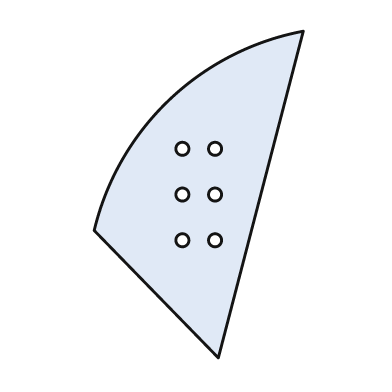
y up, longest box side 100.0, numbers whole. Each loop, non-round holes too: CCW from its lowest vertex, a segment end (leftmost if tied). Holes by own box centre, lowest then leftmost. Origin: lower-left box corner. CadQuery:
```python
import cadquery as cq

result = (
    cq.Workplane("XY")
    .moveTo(38.0, 0.0)
    .lineTo(64.0, 100.0)
    .threePointArc((23.0, 79.0), (0.0, 39.0))
    .close()
    .moveTo(27.0, 36.0)
    .circle(2.0)
    .moveTo(37.0, 36.0)
    .circle(2.0)
    .moveTo(27.0, 50.0)
    .circle(2.0)
    .moveTo(37.0, 50.0)
    .circle(2.0)
    .moveTo(27.0, 64.0)
    .circle(2.0)
    .moveTo(37.0, 64.0)
    .circle(2.0)
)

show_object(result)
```